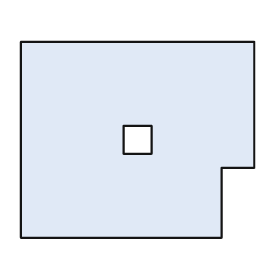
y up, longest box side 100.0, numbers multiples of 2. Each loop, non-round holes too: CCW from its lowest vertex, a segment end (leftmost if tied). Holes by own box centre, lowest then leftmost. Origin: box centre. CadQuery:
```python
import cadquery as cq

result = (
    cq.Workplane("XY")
    .moveTo(-50.0, -42.0)
    .lineTo(36.0, -42.0)
    .lineTo(36.0, -12.0)
    .lineTo(50.0, -12.0)
    .lineTo(50.0, 42.0)
    .lineTo(-50.0, 42.0)
    .close()
    .moveTo(-6.0, -6.0)
    .lineTo(6.0, -6.0)
    .lineTo(6.0, 6.0)
    .lineTo(-6.0, 6.0)
    .close()
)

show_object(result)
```